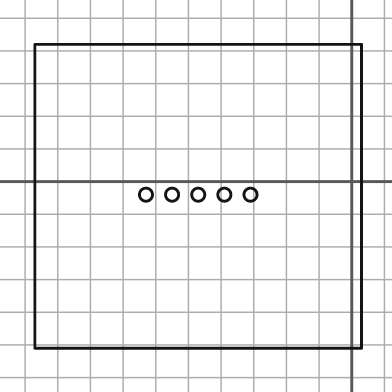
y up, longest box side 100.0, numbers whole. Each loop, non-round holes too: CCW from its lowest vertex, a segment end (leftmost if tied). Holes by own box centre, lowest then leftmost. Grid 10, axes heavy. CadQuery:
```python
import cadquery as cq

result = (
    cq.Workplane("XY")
    .moveTo(-97.0, -51.0)
    .lineTo(3.0, -51.0)
    .lineTo(3.0, 42.0)
    .lineTo(-97.0, 42.0)
    .close()
    .moveTo(-63.0, -4.0)
    .circle(2.0)
    .moveTo(-55.0, -4.0)
    .circle(2.0)
    .moveTo(-47.0, -4.0)
    .circle(2.0)
    .moveTo(-39.0, -4.0)
    .circle(2.0)
    .moveTo(-31.0, -4.0)
    .circle(2.0)
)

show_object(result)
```